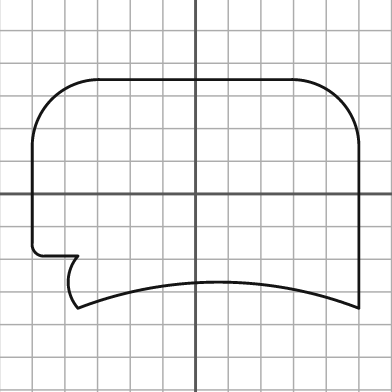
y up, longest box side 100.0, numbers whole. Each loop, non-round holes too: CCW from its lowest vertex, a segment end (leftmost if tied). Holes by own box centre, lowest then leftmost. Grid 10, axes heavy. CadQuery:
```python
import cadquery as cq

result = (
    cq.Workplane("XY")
    .moveTo(-36.0, -35.0)
    .threePointArc((7.0, -27.0), (50.0, -35.0))
    .lineTo(50.0, 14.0)
    .threePointArc((44.0, 29.0), (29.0, 35.0))
    .lineTo(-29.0, 35.0)
    .threePointArc((-44.0, 29.0), (-50.0, 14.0))
    .lineTo(-50.0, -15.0)
    .threePointArc((-49.0, -18.0), (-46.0, -19.0))
    .lineTo(-36.0, -19.0)
    .threePointArc((-39.0, -27.0), (-36.0, -35.0))
    .close()
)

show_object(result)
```